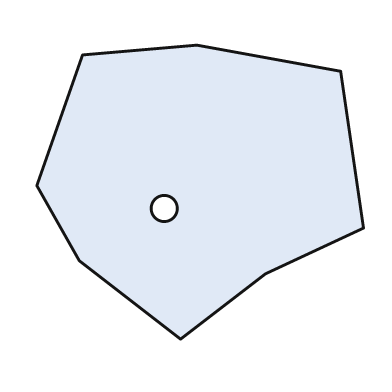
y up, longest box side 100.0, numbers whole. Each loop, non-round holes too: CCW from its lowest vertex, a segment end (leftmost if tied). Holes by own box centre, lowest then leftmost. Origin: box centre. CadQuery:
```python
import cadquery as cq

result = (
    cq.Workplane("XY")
    .moveTo(-6.0, -45.0)
    .lineTo(20.0, -25.0)
    .lineTo(50.0, -11.0)
    .lineTo(43.0, 37.0)
    .lineTo(-1.0, 45.0)
    .lineTo(-36.0, 42.0)
    .lineTo(-50.0, 2.0)
    .lineTo(-37.0, -21.0)
    .close()
    .moveTo(-11.0, -5.0)
    .circle(4.0)
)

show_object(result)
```